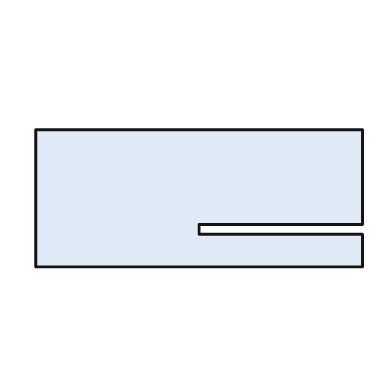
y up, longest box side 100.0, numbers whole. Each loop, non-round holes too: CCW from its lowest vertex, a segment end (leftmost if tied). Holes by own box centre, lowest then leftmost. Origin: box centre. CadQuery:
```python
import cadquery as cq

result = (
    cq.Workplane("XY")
    .moveTo(-50.0, -21.0)
    .lineTo(50.0, -21.0)
    .lineTo(50.0, -11.0)
    .lineTo(0.0, -11.0)
    .lineTo(0.0, -8.0)
    .lineTo(50.0, -8.0)
    .lineTo(50.0, 21.0)
    .lineTo(-50.0, 21.0)
    .close()
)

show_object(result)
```